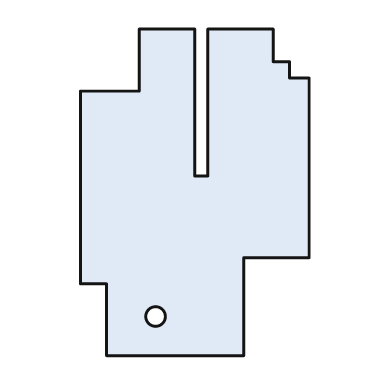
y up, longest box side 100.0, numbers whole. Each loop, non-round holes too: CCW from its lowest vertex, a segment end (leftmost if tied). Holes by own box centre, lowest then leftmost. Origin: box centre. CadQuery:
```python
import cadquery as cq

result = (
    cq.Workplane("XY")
    .moveTo(-27.0, -50.0)
    .lineTo(15.0, -50.0)
    .lineTo(15.0, -20.0)
    .lineTo(35.0, -20.0)
    .lineTo(35.0, 35.0)
    .lineTo(29.0, 35.0)
    .lineTo(29.0, 40.0)
    .lineTo(24.0, 40.0)
    .lineTo(24.0, 50.0)
    .lineTo(4.0, 50.0)
    .lineTo(4.0, 5.0)
    .lineTo(0.0, 5.0)
    .lineTo(0.0, 50.0)
    .lineTo(-17.0, 50.0)
    .lineTo(-17.0, 31.0)
    .lineTo(-35.0, 31.0)
    .lineTo(-35.0, -28.0)
    .lineTo(-27.0, -28.0)
    .close()
    .moveTo(-12.0, -38.0)
    .circle(3.0)
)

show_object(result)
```